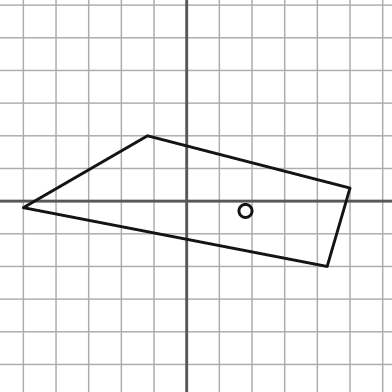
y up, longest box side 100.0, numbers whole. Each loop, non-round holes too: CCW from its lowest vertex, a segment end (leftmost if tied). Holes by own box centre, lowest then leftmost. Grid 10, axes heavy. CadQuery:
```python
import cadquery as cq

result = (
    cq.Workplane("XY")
    .moveTo(43.0, -20.0)
    .lineTo(50.0, 4.0)
    .lineTo(-12.0, 20.0)
    .lineTo(-50.0, -2.0)
    .close()
    .moveTo(18.0, -3.0)
    .circle(2.0)
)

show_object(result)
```